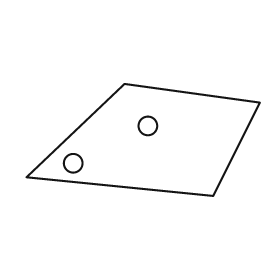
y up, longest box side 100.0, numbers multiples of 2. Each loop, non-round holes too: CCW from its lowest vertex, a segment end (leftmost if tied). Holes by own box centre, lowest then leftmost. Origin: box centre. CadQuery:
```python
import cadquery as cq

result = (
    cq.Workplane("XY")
    .moveTo(30.0, -24.0)
    .lineTo(50.0, 16.0)
    .lineTo(-8.0, 24.0)
    .lineTo(-50.0, -16.0)
    .close()
    .moveTo(-30.0, -10.0)
    .circle(4.0)
    .moveTo(2.0, 6.0)
    .circle(4.0)
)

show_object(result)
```